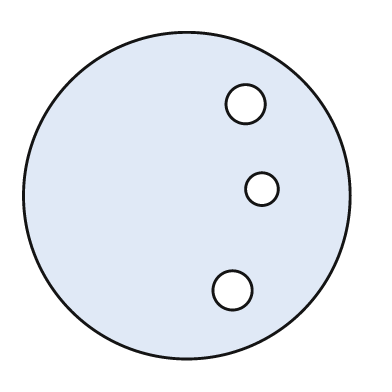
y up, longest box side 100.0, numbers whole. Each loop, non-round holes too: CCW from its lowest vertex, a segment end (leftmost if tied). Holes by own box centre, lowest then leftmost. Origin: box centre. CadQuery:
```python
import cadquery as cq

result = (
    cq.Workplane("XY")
    .moveTo(0.0, 0.0)
    .circle(50.0)
    .moveTo(14.0, -29.0)
    .circle(6.0)
    .moveTo(23.0, 2.0)
    .circle(5.0)
    .moveTo(18.0, 28.0)
    .circle(6.0)
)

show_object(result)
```